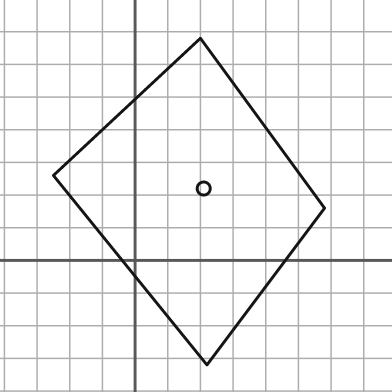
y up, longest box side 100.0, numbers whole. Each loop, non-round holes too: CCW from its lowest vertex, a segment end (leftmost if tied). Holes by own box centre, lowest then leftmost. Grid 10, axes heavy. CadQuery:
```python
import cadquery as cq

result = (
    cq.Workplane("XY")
    .moveTo(22.0, -32.0)
    .lineTo(58.0, 16.0)
    .lineTo(20.0, 68.0)
    .lineTo(-25.0, 26.0)
    .close()
    .moveTo(21.0, 22.0)
    .circle(2.0)
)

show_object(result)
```